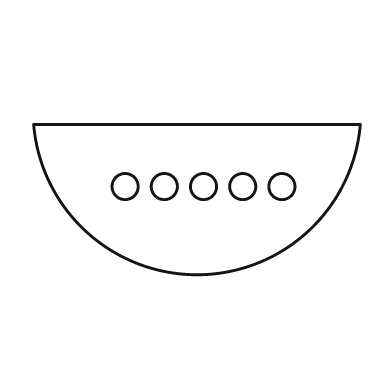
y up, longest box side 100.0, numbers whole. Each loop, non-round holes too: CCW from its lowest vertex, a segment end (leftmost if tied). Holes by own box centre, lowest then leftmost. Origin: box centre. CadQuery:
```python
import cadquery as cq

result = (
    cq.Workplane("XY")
    .moveTo(-50.0, 23.0)
    .threePointArc((0.0, -23.0), (50.0, 23.0))
    .close()
    .moveTo(-22.0, 4.0)
    .circle(4.0)
    .moveTo(-10.0, 4.0)
    .circle(4.0)
    .moveTo(2.0, 4.0)
    .circle(4.0)
    .moveTo(14.0, 4.0)
    .circle(4.0)
    .moveTo(26.0, 4.0)
    .circle(4.0)
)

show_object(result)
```